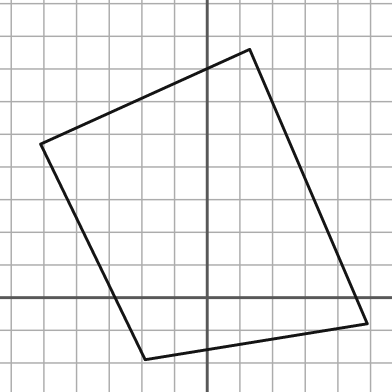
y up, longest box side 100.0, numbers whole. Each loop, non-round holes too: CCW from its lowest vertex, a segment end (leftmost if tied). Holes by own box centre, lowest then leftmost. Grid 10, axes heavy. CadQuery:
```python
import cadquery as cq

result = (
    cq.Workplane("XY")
    .moveTo(-19.0, -19.0)
    .lineTo(49.0, -8.0)
    .lineTo(13.0, 76.0)
    .lineTo(-51.0, 47.0)
    .close()
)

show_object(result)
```